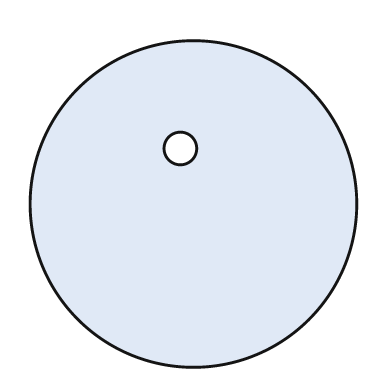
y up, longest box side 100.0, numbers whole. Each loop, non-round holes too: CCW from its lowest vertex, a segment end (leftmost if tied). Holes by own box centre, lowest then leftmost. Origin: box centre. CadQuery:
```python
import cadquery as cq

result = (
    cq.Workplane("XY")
    .moveTo(0.0, 0.0)
    .circle(50.0)
    .moveTo(-4.0, 17.0)
    .circle(5.0)
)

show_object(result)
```